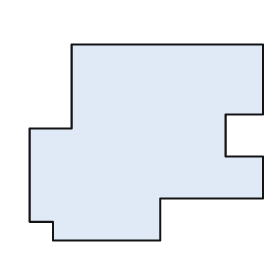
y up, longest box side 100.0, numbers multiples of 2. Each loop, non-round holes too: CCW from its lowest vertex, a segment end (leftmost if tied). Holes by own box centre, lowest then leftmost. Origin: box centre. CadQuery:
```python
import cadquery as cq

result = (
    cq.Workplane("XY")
    .moveTo(-40.0, -42.0)
    .lineTo(6.0, -42.0)
    .lineTo(6.0, -24.0)
    .lineTo(50.0, -24.0)
    .lineTo(50.0, -6.0)
    .lineTo(34.0, -6.0)
    .lineTo(34.0, 12.0)
    .lineTo(50.0, 12.0)
    .lineTo(50.0, 42.0)
    .lineTo(-32.0, 42.0)
    .lineTo(-32.0, 6.0)
    .lineTo(-50.0, 6.0)
    .lineTo(-50.0, -34.0)
    .lineTo(-40.0, -34.0)
    .close()
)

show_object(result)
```